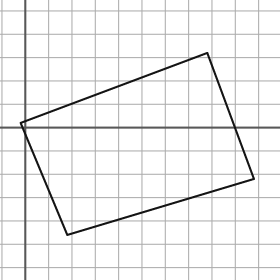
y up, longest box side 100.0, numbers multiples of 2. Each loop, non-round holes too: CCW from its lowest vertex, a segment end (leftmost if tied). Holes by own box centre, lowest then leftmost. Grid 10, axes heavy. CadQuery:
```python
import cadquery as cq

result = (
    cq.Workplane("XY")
    .moveTo(18.0, -46.0)
    .lineTo(98.0, -22.0)
    .lineTo(78.0, 32.0)
    .lineTo(-2.0, 2.0)
    .close()
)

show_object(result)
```